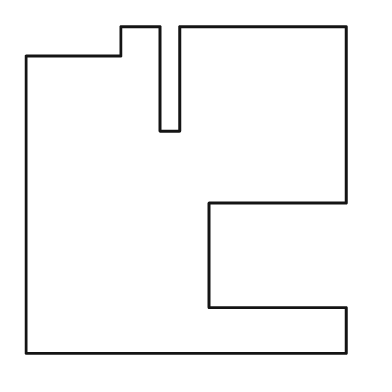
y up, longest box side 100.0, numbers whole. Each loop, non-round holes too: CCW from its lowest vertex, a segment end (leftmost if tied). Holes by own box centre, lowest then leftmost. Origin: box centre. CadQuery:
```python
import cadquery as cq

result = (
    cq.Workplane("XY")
    .moveTo(-49.0, -50.0)
    .lineTo(49.0, -50.0)
    .lineTo(49.0, -36.0)
    .lineTo(7.0, -36.0)
    .lineTo(7.0, -4.0)
    .lineTo(49.0, -4.0)
    .lineTo(49.0, 50.0)
    .lineTo(-2.0, 50.0)
    .lineTo(-2.0, 18.0)
    .lineTo(-8.0, 18.0)
    .lineTo(-8.0, 50.0)
    .lineTo(-20.0, 50.0)
    .lineTo(-20.0, 41.0)
    .lineTo(-49.0, 41.0)
    .close()
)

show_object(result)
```